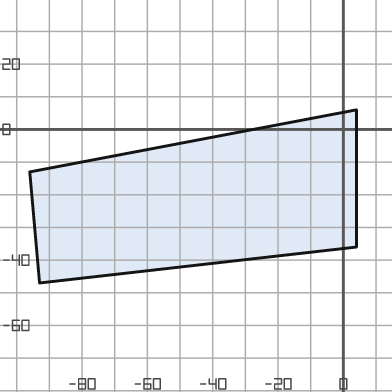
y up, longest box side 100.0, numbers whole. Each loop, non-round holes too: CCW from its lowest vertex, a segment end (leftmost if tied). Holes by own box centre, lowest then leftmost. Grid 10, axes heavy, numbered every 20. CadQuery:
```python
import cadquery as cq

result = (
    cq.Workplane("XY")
    .moveTo(-93.0, -47.0)
    .lineTo(4.0, -36.0)
    .lineTo(4.0, 6.0)
    .lineTo(-96.0, -13.0)
    .close()
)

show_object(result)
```